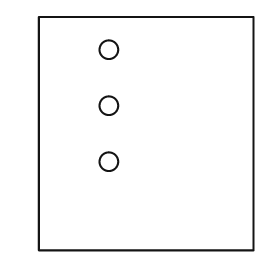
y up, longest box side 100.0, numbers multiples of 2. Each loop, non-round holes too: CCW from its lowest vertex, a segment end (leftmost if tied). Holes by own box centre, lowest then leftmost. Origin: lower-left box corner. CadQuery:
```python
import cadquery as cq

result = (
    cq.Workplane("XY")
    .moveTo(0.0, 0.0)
    .lineTo(92.0, 0.0)
    .lineTo(92.0, 100.0)
    .lineTo(0.0, 100.0)
    .close()
    .moveTo(30.0, 38.0)
    .circle(4.0)
    .moveTo(30.0, 62.0)
    .circle(4.0)
    .moveTo(30.0, 86.0)
    .circle(4.0)
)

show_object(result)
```